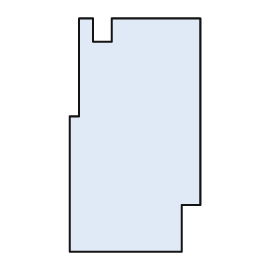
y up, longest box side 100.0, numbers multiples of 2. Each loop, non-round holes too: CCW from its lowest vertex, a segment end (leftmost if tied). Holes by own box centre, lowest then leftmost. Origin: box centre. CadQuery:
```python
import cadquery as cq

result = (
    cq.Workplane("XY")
    .moveTo(-28.0, -50.0)
    .lineTo(20.0, -50.0)
    .lineTo(20.0, -30.0)
    .lineTo(28.0, -30.0)
    .lineTo(28.0, 50.0)
    .lineTo(-10.0, 50.0)
    .lineTo(-10.0, 40.0)
    .lineTo(-18.0, 40.0)
    .lineTo(-18.0, 50.0)
    .lineTo(-24.0, 50.0)
    .lineTo(-24.0, 8.0)
    .lineTo(-28.0, 8.0)
    .close()
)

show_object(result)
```